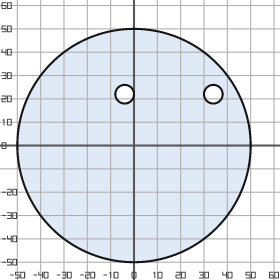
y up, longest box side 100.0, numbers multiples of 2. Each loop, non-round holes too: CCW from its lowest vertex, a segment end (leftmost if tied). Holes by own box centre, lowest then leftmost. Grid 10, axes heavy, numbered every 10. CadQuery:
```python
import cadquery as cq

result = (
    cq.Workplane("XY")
    .moveTo(0.0, 0.0)
    .circle(50.0)
    .moveTo(-4.0, 22.0)
    .circle(4.0)
    .moveTo(34.0, 22.0)
    .circle(4.0)
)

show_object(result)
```